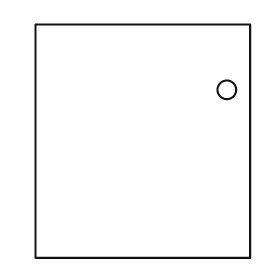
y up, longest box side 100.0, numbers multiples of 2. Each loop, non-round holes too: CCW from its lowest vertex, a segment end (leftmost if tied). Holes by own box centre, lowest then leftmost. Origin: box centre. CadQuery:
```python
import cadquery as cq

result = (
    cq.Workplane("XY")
    .moveTo(-46.0, -50.0)
    .lineTo(46.0, -50.0)
    .lineTo(46.0, 50.0)
    .lineTo(-46.0, 50.0)
    .close()
    .moveTo(36.0, 22.0)
    .circle(4.0)
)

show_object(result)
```